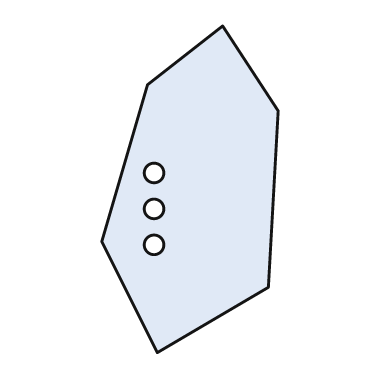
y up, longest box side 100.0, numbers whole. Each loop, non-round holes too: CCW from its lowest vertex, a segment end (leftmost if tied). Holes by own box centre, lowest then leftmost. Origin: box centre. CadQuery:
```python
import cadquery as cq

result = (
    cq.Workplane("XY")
    .moveTo(-10.0, -50.0)
    .lineTo(24.0, -30.0)
    .lineTo(27.0, 24.0)
    .lineTo(10.0, 50.0)
    .lineTo(-13.0, 32.0)
    .lineTo(-27.0, -16.0)
    .close()
    .moveTo(-11.0, -17.0)
    .circle(3.0)
    .moveTo(-11.0, -6.0)
    .circle(3.0)
    .moveTo(-11.0, 5.0)
    .circle(3.0)
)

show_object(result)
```